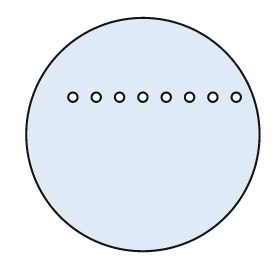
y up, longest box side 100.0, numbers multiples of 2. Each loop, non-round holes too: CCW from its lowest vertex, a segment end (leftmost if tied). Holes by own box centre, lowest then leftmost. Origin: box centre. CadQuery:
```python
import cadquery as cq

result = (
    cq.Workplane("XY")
    .moveTo(0.0, 0.0)
    .circle(50.0)
    .moveTo(-30.0, 16.0)
    .circle(2.0)
    .moveTo(-20.0, 16.0)
    .circle(2.0)
    .moveTo(-10.0, 16.0)
    .circle(2.0)
    .moveTo(0.0, 16.0)
    .circle(2.0)
    .moveTo(10.0, 16.0)
    .circle(2.0)
    .moveTo(20.0, 16.0)
    .circle(2.0)
    .moveTo(30.0, 16.0)
    .circle(2.0)
    .moveTo(40.0, 16.0)
    .circle(2.0)
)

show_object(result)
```